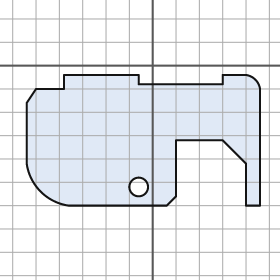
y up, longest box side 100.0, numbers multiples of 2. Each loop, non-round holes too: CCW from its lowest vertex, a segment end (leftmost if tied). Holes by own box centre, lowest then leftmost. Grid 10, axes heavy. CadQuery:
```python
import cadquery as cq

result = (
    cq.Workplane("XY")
    .moveTo(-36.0, -60.0)
    .lineTo(6.0, -60.0)
    .lineTo(10.0, -56.0)
    .lineTo(10.0, -32.0)
    .lineTo(30.0, -32.0)
    .lineTo(40.0, -42.0)
    .lineTo(40.0, -60.0)
    .lineTo(46.0, -60.0)
    .lineTo(46.0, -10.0)
    .threePointArc((44.0, -6.0), (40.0, -4.0))
    .lineTo(30.0, -4.0)
    .lineTo(30.0, -8.0)
    .lineTo(-6.0, -8.0)
    .lineTo(-6.0, -4.0)
    .lineTo(-38.0, -4.0)
    .lineTo(-38.0, -10.0)
    .lineTo(-50.0, -10.0)
    .lineTo(-54.0, -16.0)
    .lineTo(-54.0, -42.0)
    .threePointArc((-48.0, -54.0), (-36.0, -60.0))
    .close()
    .moveTo(-6.0, -52.0)
    .circle(4.0)
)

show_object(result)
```